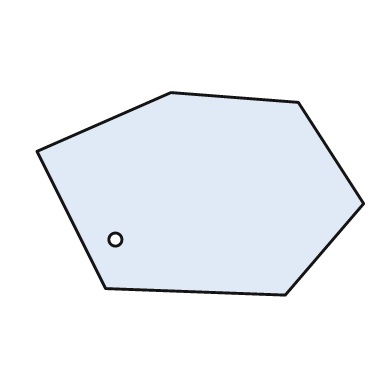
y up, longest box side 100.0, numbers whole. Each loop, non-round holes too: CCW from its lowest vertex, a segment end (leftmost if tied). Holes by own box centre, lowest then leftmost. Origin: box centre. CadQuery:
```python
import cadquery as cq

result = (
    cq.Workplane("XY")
    .moveTo(26.0, -31.0)
    .lineTo(50.0, -3.0)
    .lineTo(30.0, 28.0)
    .lineTo(-9.0, 31.0)
    .lineTo(-50.0, 13.0)
    .lineTo(-29.0, -29.0)
    .close()
    .moveTo(-26.0, -14.0)
    .circle(2.0)
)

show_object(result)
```